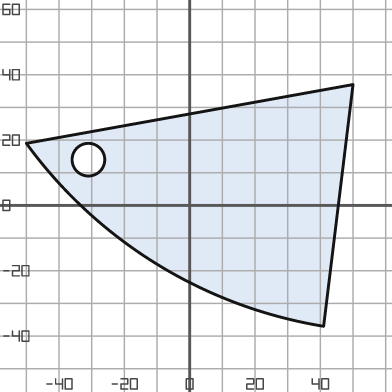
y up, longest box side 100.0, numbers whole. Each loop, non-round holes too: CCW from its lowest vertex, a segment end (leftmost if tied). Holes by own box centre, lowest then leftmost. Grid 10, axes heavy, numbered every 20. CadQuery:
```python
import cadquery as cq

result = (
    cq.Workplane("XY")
    .moveTo(41.0, -37.0)
    .lineTo(50.0, 37.0)
    .lineTo(-50.0, 19.0)
    .threePointArc((-10.0, -18.0), (41.0, -37.0))
    .close()
    .moveTo(-31.0, 14.0)
    .circle(5.0)
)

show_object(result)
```